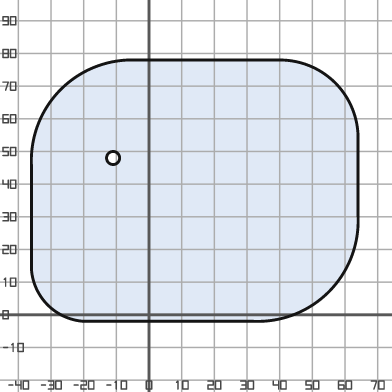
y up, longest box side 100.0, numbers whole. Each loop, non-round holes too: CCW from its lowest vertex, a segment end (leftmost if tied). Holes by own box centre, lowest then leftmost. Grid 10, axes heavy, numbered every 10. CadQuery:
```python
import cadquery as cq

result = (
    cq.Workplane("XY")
    .moveTo(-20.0, -2.0)
    .lineTo(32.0, -2.0)
    .threePointArc((55.0, 7.0), (64.0, 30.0))
    .lineTo(64.0, 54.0)
    .threePointArc((57.0, 71.0), (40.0, 78.0))
    .lineTo(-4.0, 78.0)
    .threePointArc((-27.0, 69.0), (-36.0, 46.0))
    .lineTo(-36.0, 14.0)
    .threePointArc((-31.0, 3.0), (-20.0, -2.0))
    .close()
    .moveTo(-11.0, 48.0)
    .circle(2.0)
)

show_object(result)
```